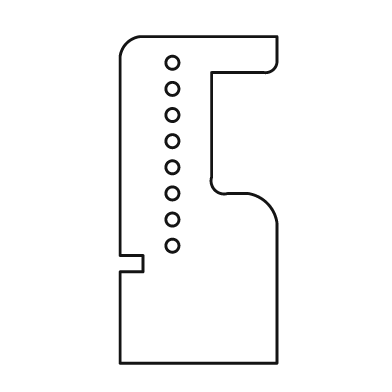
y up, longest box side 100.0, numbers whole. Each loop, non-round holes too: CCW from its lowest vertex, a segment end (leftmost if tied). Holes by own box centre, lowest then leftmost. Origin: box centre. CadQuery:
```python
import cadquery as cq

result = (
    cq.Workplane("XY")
    .moveTo(-24.0, -50.0)
    .lineTo(24.0, -50.0)
    .lineTo(24.0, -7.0)
    .threePointArc((21.0, -1.0), (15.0, 2.0))
    .lineTo(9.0, 2.0)
    .threePointArc((5.0, 3.0), (4.0, 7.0))
    .lineTo(4.0, 39.0)
    .lineTo(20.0, 39.0)
    .threePointArc((23.0, 40.0), (24.0, 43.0))
    .lineTo(24.0, 50.0)
    .lineTo(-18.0, 50.0)
    .threePointArc((-22.0, 48.0), (-24.0, 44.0))
    .lineTo(-24.0, -17.0)
    .lineTo(-17.0, -17.0)
    .lineTo(-17.0, -22.0)
    .lineTo(-24.0, -22.0)
    .close()
    .moveTo(-8.0, -14.0)
    .circle(2.0)
    .moveTo(-8.0, -6.0)
    .circle(2.0)
    .moveTo(-8.0, 2.0)
    .circle(2.0)
    .moveTo(-8.0, 10.0)
    .circle(2.0)
    .moveTo(-8.0, 18.0)
    .circle(2.0)
    .moveTo(-8.0, 26.0)
    .circle(2.0)
    .moveTo(-8.0, 34.0)
    .circle(2.0)
    .moveTo(-8.0, 42.0)
    .circle(2.0)
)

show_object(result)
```